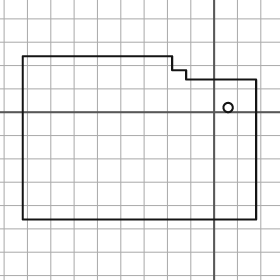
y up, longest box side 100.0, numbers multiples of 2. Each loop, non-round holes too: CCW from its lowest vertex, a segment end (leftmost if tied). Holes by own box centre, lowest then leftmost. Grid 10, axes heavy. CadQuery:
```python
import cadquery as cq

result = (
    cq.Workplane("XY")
    .moveTo(-82.0, -46.0)
    .lineTo(18.0, -46.0)
    .lineTo(18.0, 14.0)
    .lineTo(-12.0, 14.0)
    .lineTo(-12.0, 18.0)
    .lineTo(-18.0, 18.0)
    .lineTo(-18.0, 24.0)
    .lineTo(-82.0, 24.0)
    .close()
    .moveTo(6.0, 2.0)
    .circle(2.0)
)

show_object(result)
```